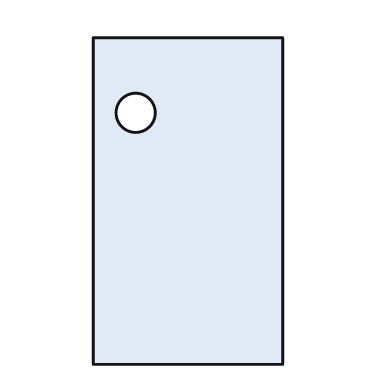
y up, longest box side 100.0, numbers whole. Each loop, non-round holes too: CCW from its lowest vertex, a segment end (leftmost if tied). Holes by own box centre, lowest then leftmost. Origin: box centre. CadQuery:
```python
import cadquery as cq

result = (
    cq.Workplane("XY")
    .moveTo(-29.0, -50.0)
    .lineTo(29.0, -50.0)
    .lineTo(29.0, 50.0)
    .lineTo(-29.0, 50.0)
    .close()
    .moveTo(-16.0, 27.0)
    .circle(6.0)
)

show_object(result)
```